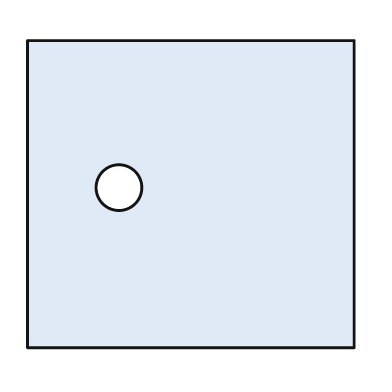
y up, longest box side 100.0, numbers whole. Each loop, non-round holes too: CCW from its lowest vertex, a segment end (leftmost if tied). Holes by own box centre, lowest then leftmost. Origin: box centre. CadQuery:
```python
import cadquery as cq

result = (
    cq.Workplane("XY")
    .moveTo(-50.0, -47.0)
    .lineTo(50.0, -47.0)
    .lineTo(50.0, 47.0)
    .lineTo(-50.0, 47.0)
    .close()
    .moveTo(-22.0, 2.0)
    .circle(7.0)
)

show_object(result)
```